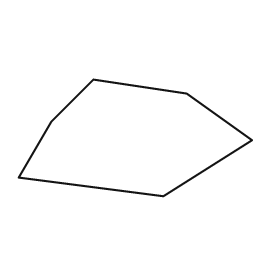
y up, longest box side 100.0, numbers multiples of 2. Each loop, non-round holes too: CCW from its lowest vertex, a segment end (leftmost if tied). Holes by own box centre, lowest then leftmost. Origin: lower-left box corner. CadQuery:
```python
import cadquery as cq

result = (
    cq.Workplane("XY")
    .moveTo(62.0, 0.0)
    .lineTo(100.0, 24.0)
    .lineTo(72.0, 44.0)
    .lineTo(32.0, 50.0)
    .lineTo(14.0, 32.0)
    .lineTo(0.0, 8.0)
    .close()
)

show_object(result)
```